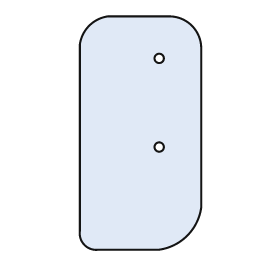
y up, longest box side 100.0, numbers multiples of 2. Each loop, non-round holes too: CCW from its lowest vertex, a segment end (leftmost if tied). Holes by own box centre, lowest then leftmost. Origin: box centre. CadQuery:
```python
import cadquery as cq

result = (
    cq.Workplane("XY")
    .moveTo(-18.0, -50.0)
    .lineTo(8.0, -50.0)
    .threePointArc((20.0, -44.0), (26.0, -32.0))
    .lineTo(26.0, 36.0)
    .threePointArc((22.0, 46.0), (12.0, 50.0))
    .lineTo(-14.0, 50.0)
    .threePointArc((-22.0, 46.0), (-26.0, 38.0))
    .lineTo(-26.0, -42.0)
    .threePointArc((-24.0, -48.0), (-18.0, -50.0))
    .close()
    .moveTo(8.0, -6.0)
    .circle(2.0)
    .moveTo(8.0, 32.0)
    .circle(2.0)
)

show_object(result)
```